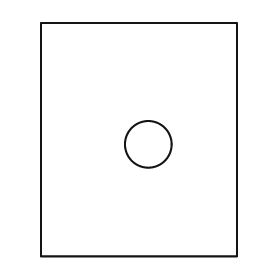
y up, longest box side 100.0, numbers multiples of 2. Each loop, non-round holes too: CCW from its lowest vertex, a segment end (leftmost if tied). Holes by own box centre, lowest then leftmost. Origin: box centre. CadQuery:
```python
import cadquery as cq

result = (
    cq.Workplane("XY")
    .moveTo(-42.0, -50.0)
    .lineTo(42.0, -50.0)
    .lineTo(42.0, 50.0)
    .lineTo(-42.0, 50.0)
    .close()
    .moveTo(4.0, -2.0)
    .circle(10.0)
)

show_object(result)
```